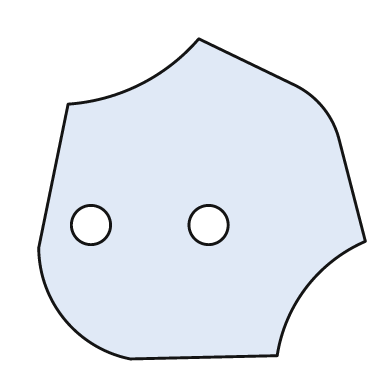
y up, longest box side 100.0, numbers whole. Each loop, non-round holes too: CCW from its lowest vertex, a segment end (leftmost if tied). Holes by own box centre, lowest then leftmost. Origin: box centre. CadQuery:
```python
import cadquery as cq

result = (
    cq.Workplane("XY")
    .moveTo(-22.0, -49.0)
    .lineTo(23.0, -48.0)
    .threePointArc((32.0, -27.0), (50.0, -13.0))
    .lineTo(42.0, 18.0)
    .threePointArc((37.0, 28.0), (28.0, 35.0))
    .lineTo(-1.0, 49.0)
    .threePointArc((-19.0, 35.0), (-41.0, 29.0))
    .lineTo(-50.0, -15.0)
    .threePointArc((-42.0, -37.0), (-22.0, -49.0))
    .close()
    .moveTo(-34.0, -8.0)
    .circle(6.0)
    .moveTo(2.0, -8.0)
    .circle(6.0)
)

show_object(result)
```